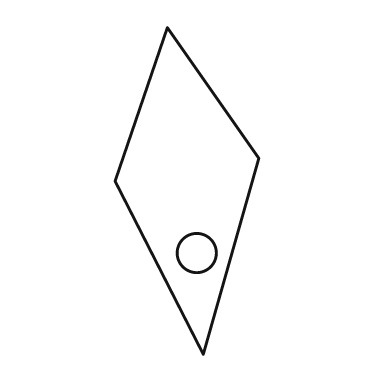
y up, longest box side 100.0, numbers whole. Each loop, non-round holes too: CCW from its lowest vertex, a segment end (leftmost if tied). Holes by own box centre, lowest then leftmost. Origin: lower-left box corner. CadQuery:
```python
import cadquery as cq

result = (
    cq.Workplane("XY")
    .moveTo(27.0, 0.0)
    .lineTo(44.0, 60.0)
    .lineTo(16.0, 100.0)
    .lineTo(0.0, 53.0)
    .close()
    .moveTo(25.0, 31.0)
    .circle(6.0)
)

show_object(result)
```